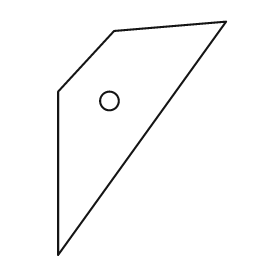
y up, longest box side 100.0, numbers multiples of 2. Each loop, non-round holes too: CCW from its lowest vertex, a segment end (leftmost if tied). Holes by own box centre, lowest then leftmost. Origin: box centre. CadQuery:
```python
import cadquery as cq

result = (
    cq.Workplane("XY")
    .moveTo(-36.0, -50.0)
    .lineTo(36.0, 50.0)
    .lineTo(-12.0, 46.0)
    .lineTo(-36.0, 20.0)
    .close()
    .moveTo(-14.0, 16.0)
    .circle(4.0)
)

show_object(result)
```